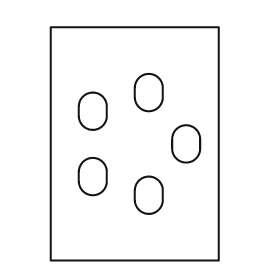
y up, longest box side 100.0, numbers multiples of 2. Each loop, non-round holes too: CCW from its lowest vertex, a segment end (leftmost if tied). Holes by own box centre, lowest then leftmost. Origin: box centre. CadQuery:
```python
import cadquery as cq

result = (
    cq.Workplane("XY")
    .moveTo(-36.0, -50.0)
    .lineTo(36.0, -50.0)
    .lineTo(36.0, 50.0)
    .lineTo(-36.0, 50.0)
    .close()
    .moveTo(0.0, -24.0)
    .threePointArc((6.0, -30.0), (12.0, -24.0))
    .lineTo(12.0, -20.0)
    .threePointArc((6.0, -14.0), (0.0, -20.0))
    .close()
    .moveTo(-24.0, -16.0)
    .threePointArc((-18.0, -22.0), (-12.0, -16.0))
    .lineTo(-12.0, -12.0)
    .threePointArc((-18.0, -6.0), (-24.0, -12.0))
    .close()
    .moveTo(16.0, -2.0)
    .threePointArc((22.0, -8.0), (28.0, -2.0))
    .lineTo(28.0, 2.0)
    .threePointArc((22.0, 8.0), (16.0, 2.0))
    .close()
    .moveTo(-24.0, 12.0)
    .threePointArc((-18.0, 6.0), (-12.0, 12.0))
    .lineTo(-12.0, 16.0)
    .threePointArc((-18.0, 22.0), (-24.0, 16.0))
    .close()
    .moveTo(0.0, 20.0)
    .threePointArc((6.0, 14.0), (12.0, 20.0))
    .lineTo(12.0, 24.0)
    .threePointArc((6.0, 30.0), (0.0, 24.0))
    .close()
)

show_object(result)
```